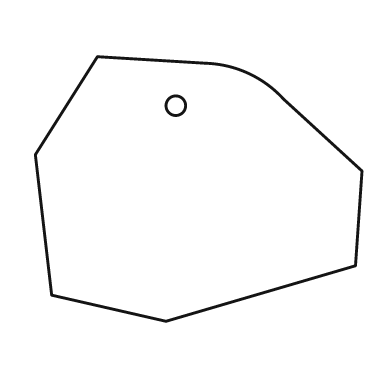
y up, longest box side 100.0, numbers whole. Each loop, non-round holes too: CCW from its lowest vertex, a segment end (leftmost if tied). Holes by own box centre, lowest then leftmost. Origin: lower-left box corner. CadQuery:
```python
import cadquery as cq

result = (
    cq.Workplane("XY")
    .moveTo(40.0, 0.0)
    .lineTo(98.0, 17.0)
    .lineTo(100.0, 46.0)
    .lineTo(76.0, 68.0)
    .threePointArc((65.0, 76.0), (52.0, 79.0))
    .lineTo(19.0, 81.0)
    .lineTo(0.0, 51.0)
    .lineTo(5.0, 8.0)
    .close()
    .moveTo(43.0, 66.0)
    .circle(3.0)
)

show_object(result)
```